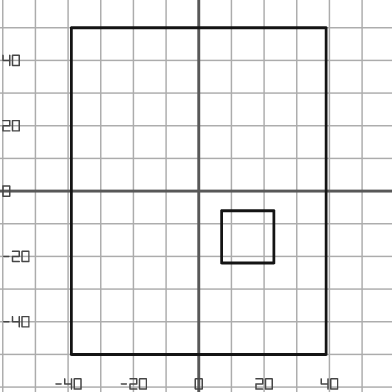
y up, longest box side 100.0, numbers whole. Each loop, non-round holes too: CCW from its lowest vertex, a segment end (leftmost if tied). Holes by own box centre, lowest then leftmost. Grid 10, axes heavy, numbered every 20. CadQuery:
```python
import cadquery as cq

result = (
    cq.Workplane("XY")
    .moveTo(-39.0, -50.0)
    .lineTo(39.0, -50.0)
    .lineTo(39.0, 50.0)
    .lineTo(-39.0, 50.0)
    .close()
    .moveTo(7.0, -22.0)
    .lineTo(23.0, -22.0)
    .lineTo(23.0, -6.0)
    .lineTo(7.0, -6.0)
    .close()
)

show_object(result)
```